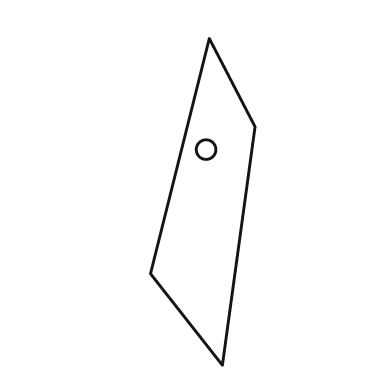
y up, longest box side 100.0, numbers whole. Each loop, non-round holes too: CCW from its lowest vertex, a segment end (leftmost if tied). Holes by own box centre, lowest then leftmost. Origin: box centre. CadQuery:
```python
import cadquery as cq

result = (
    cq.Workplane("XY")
    .moveTo(6.0, -50.0)
    .lineTo(16.0, 23.0)
    .lineTo(2.0, 50.0)
    .lineTo(-16.0, -22.0)
    .close()
    .moveTo(1.0, 16.0)
    .circle(3.0)
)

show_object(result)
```